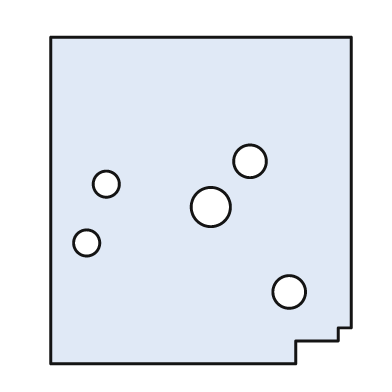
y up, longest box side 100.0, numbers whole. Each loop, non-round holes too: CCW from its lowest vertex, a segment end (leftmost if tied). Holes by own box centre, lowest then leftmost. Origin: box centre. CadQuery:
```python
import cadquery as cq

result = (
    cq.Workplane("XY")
    .moveTo(-46.0, -50.0)
    .lineTo(29.0, -50.0)
    .lineTo(29.0, -43.0)
    .lineTo(42.0, -43.0)
    .lineTo(42.0, -39.0)
    .lineTo(46.0, -39.0)
    .lineTo(46.0, 50.0)
    .lineTo(-46.0, 50.0)
    .close()
    .moveTo(27.0, -28.0)
    .circle(5.0)
    .moveTo(-35.0, -13.0)
    .circle(4.0)
    .moveTo(3.0, -2.0)
    .circle(6.0)
    .moveTo(-29.0, 5.0)
    .circle(4.0)
    .moveTo(15.0, 12.0)
    .circle(5.0)
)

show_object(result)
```